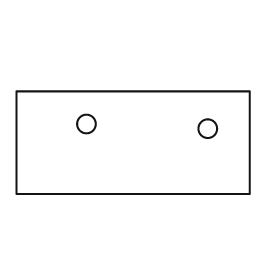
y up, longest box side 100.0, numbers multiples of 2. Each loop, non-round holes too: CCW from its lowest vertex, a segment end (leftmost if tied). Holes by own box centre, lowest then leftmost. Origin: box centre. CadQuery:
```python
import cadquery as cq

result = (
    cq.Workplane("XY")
    .moveTo(-50.0, -22.0)
    .lineTo(50.0, -22.0)
    .lineTo(50.0, 22.0)
    .lineTo(-50.0, 22.0)
    .close()
    .moveTo(32.0, 6.0)
    .circle(4.0)
    .moveTo(-20.0, 8.0)
    .circle(4.0)
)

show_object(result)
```